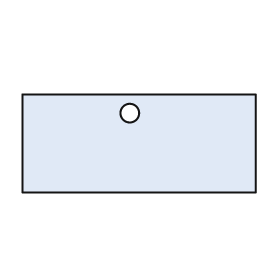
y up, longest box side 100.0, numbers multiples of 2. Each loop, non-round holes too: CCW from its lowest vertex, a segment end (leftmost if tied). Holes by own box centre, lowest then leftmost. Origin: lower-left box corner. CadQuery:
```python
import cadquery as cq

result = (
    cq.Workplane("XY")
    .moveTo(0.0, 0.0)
    .lineTo(100.0, 0.0)
    .lineTo(100.0, 42.0)
    .lineTo(0.0, 42.0)
    .close()
    .moveTo(46.0, 34.0)
    .circle(4.0)
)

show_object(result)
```